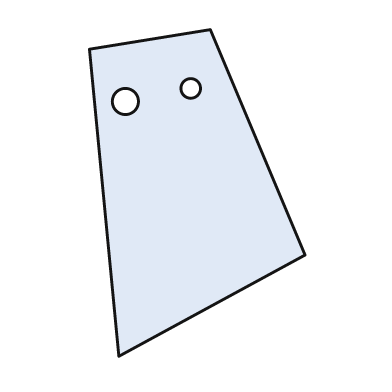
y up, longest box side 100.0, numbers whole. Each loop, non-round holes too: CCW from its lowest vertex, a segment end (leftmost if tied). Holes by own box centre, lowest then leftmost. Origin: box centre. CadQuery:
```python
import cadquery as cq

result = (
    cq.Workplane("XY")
    .moveTo(-24.0, -50.0)
    .lineTo(33.0, -19.0)
    .lineTo(4.0, 50.0)
    .lineTo(-33.0, 44.0)
    .close()
    .moveTo(-22.0, 28.0)
    .circle(4.0)
    .moveTo(-2.0, 32.0)
    .circle(3.0)
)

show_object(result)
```